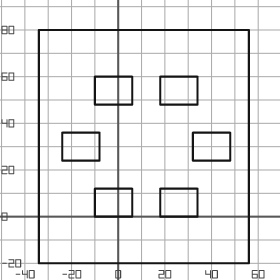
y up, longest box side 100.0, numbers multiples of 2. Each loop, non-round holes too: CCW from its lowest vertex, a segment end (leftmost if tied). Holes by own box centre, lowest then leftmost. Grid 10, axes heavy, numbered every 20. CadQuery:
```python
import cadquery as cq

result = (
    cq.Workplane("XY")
    .moveTo(-34.0, -20.0)
    .lineTo(56.0, -20.0)
    .lineTo(56.0, 80.0)
    .lineTo(-34.0, 80.0)
    .close()
    .moveTo(-10.0, 0.0)
    .lineTo(6.0, 0.0)
    .lineTo(6.0, 12.0)
    .lineTo(-10.0, 12.0)
    .close()
    .moveTo(18.0, 0.0)
    .lineTo(34.0, 0.0)
    .lineTo(34.0, 12.0)
    .lineTo(18.0, 12.0)
    .close()
    .moveTo(-24.0, 24.0)
    .lineTo(-8.0, 24.0)
    .lineTo(-8.0, 36.0)
    .lineTo(-24.0, 36.0)
    .close()
    .moveTo(32.0, 24.0)
    .lineTo(48.0, 24.0)
    .lineTo(48.0, 36.0)
    .lineTo(32.0, 36.0)
    .close()
    .moveTo(-10.0, 48.0)
    .lineTo(6.0, 48.0)
    .lineTo(6.0, 60.0)
    .lineTo(-10.0, 60.0)
    .close()
    .moveTo(18.0, 48.0)
    .lineTo(34.0, 48.0)
    .lineTo(34.0, 60.0)
    .lineTo(18.0, 60.0)
    .close()
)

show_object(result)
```